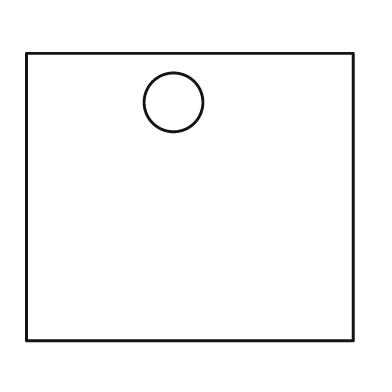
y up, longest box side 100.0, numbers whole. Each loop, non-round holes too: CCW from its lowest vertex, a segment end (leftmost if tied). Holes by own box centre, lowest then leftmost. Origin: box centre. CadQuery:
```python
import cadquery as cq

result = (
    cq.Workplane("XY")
    .moveTo(-50.0, -44.0)
    .lineTo(50.0, -44.0)
    .lineTo(50.0, 44.0)
    .lineTo(-50.0, 44.0)
    .close()
    .moveTo(-5.0, 29.0)
    .circle(9.0)
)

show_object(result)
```